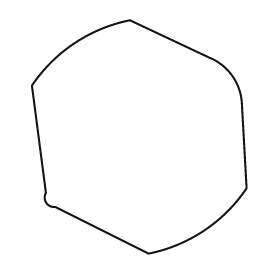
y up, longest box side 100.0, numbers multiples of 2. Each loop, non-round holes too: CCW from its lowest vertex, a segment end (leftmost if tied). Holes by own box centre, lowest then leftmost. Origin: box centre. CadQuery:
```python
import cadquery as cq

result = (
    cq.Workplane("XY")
    .moveTo(4.0, -50.0)
    .threePointArc((28.0, -40.0), (46.0, -22.0))
    .lineTo(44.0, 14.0)
    .threePointArc((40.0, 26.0), (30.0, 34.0))
    .lineTo(-4.0, 50.0)
    .threePointArc((-28.0, 40.0), (-46.0, 22.0))
    .lineTo(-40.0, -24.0)
    .threePointArc((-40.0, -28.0), (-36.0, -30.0))
    .close()
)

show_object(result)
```